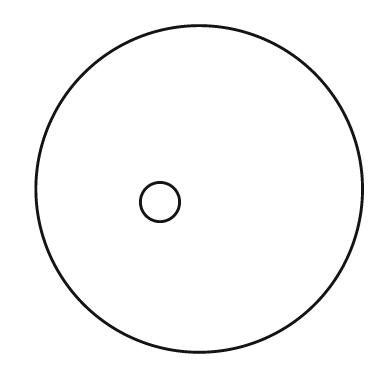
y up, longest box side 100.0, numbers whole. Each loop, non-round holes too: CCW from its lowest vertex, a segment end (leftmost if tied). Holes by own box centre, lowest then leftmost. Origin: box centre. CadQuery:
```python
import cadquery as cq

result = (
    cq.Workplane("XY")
    .moveTo(0.0, 0.0)
    .circle(50.0)
    .moveTo(-12.0, -4.0)
    .circle(6.0)
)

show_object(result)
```